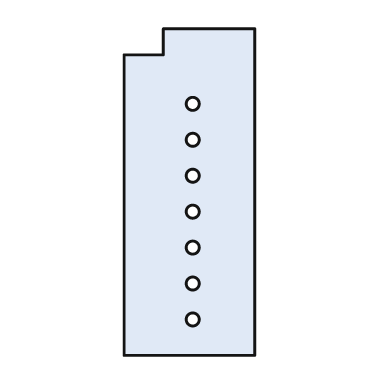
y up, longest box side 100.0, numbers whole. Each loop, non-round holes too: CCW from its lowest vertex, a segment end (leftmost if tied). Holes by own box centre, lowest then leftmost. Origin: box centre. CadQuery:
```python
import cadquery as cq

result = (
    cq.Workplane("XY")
    .moveTo(-20.0, -50.0)
    .lineTo(20.0, -50.0)
    .lineTo(20.0, 50.0)
    .lineTo(-8.0, 50.0)
    .lineTo(-8.0, 42.0)
    .lineTo(-20.0, 42.0)
    .close()
    .moveTo(1.0, -39.0)
    .circle(2.0)
    .moveTo(1.0, -28.0)
    .circle(2.0)
    .moveTo(1.0, -17.0)
    .circle(2.0)
    .moveTo(1.0, -6.0)
    .circle(2.0)
    .moveTo(1.0, 5.0)
    .circle(2.0)
    .moveTo(1.0, 16.0)
    .circle(2.0)
    .moveTo(1.0, 27.0)
    .circle(2.0)
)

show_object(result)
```